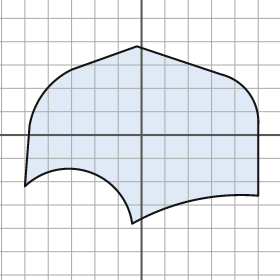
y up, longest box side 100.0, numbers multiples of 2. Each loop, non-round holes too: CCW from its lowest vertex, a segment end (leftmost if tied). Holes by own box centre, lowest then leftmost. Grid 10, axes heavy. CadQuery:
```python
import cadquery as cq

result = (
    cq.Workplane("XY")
    .moveTo(-4.0, -38.0)
    .threePointArc((22.0, -28.0), (50.0, -26.0))
    .lineTo(50.0, 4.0)
    .threePointArc((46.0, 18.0), (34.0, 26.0))
    .lineTo(-2.0, 38.0)
    .lineTo(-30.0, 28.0)
    .threePointArc((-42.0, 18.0), (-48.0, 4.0))
    .lineTo(-50.0, -22.0)
    .threePointArc((-22.0, -16.0), (-4.0, -38.0))
    .close()
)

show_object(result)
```